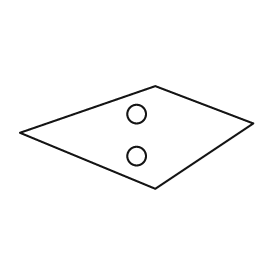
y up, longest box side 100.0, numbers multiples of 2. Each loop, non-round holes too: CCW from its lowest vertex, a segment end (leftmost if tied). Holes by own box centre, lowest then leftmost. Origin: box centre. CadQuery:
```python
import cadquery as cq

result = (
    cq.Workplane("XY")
    .moveTo(8.0, -22.0)
    .lineTo(50.0, 6.0)
    .lineTo(8.0, 22.0)
    .lineTo(-50.0, 2.0)
    .close()
    .moveTo(0.0, -8.0)
    .circle(4.0)
    .moveTo(0.0, 10.0)
    .circle(4.0)
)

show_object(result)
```